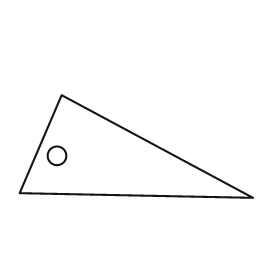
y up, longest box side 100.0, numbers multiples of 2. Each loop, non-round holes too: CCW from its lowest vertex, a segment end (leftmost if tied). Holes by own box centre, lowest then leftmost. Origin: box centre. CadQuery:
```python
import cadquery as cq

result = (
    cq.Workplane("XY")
    .moveTo(50.0, -22.0)
    .lineTo(-32.0, 22.0)
    .lineTo(-50.0, -20.0)
    .close()
    .moveTo(-34.0, -4.0)
    .circle(4.0)
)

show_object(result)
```